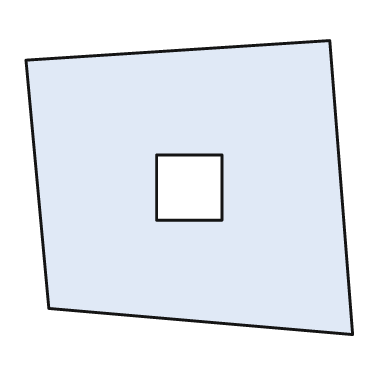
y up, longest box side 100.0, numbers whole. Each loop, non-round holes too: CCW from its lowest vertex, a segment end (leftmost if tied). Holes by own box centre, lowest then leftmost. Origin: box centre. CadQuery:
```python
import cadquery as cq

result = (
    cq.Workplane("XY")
    .moveTo(50.0, -45.0)
    .lineTo(43.0, 45.0)
    .lineTo(-50.0, 39.0)
    .lineTo(-43.0, -37.0)
    .close()
    .moveTo(-10.0, -10.0)
    .lineTo(10.0, -10.0)
    .lineTo(10.0, 10.0)
    .lineTo(-10.0, 10.0)
    .close()
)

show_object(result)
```